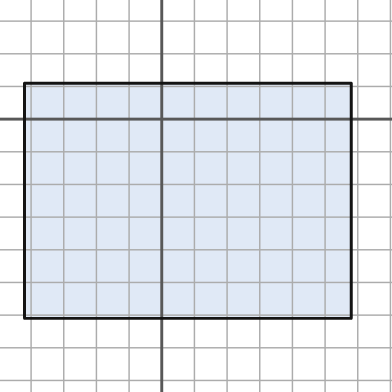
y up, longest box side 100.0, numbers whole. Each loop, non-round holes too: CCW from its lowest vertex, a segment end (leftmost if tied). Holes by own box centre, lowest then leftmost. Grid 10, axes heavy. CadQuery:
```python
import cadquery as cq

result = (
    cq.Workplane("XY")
    .moveTo(-42.0, -61.0)
    .lineTo(58.0, -61.0)
    .lineTo(58.0, 11.0)
    .lineTo(-42.0, 11.0)
    .close()
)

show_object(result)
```